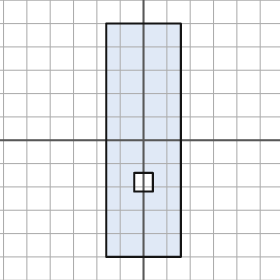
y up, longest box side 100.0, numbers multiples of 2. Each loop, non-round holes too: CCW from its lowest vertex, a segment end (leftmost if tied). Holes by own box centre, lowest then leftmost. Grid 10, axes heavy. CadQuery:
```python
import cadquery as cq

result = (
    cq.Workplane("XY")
    .moveTo(-16.0, -50.0)
    .lineTo(16.0, -50.0)
    .lineTo(16.0, 50.0)
    .lineTo(-16.0, 50.0)
    .close()
    .moveTo(-4.0, -22.0)
    .lineTo(4.0, -22.0)
    .lineTo(4.0, -14.0)
    .lineTo(-4.0, -14.0)
    .close()
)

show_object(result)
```